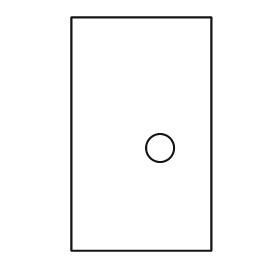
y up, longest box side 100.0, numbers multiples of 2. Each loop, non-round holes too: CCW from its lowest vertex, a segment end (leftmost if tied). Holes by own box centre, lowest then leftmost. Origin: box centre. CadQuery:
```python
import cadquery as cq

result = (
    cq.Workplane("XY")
    .moveTo(-30.0, -50.0)
    .lineTo(30.0, -50.0)
    .lineTo(30.0, 50.0)
    .lineTo(-30.0, 50.0)
    .close()
    .moveTo(8.0, -6.0)
    .circle(6.0)
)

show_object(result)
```